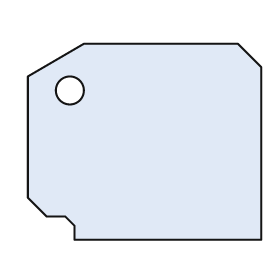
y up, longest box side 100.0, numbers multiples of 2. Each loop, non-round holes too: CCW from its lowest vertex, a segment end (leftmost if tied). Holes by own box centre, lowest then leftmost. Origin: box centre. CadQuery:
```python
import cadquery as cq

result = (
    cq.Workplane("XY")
    .moveTo(-30.0, -42.0)
    .lineTo(50.0, -42.0)
    .lineTo(50.0, 32.0)
    .lineTo(40.0, 42.0)
    .lineTo(-26.0, 42.0)
    .lineTo(-50.0, 28.0)
    .lineTo(-50.0, -24.0)
    .lineTo(-42.0, -32.0)
    .lineTo(-34.0, -32.0)
    .lineTo(-30.0, -36.0)
    .close()
    .moveTo(-32.0, 22.0)
    .circle(6.0)
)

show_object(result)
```